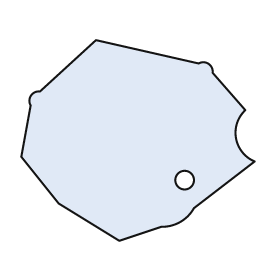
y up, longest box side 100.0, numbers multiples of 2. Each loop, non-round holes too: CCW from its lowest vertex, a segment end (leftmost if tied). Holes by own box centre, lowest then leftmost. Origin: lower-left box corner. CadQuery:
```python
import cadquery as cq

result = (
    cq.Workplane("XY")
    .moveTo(42.0, 0.0)
    .lineTo(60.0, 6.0)
    .threePointArc((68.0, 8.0), (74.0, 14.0))
    .lineTo(100.0, 34.0)
    .threePointArc((92.0, 44.0), (96.0, 56.0))
    .lineTo(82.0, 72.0)
    .threePointArc((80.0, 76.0), (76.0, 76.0))
    .lineTo(32.0, 86.0)
    .lineTo(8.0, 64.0)
    .threePointArc((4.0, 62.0), (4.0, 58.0))
    .lineTo(0.0, 36.0)
    .lineTo(16.0, 16.0)
    .close()
    .moveTo(70.0, 26.0)
    .circle(4.0)
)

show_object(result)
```